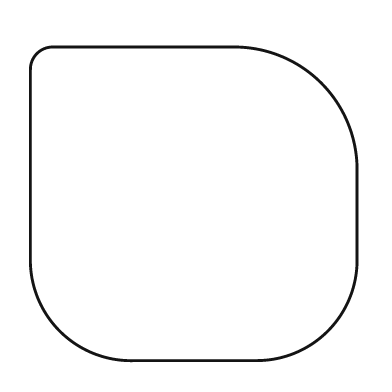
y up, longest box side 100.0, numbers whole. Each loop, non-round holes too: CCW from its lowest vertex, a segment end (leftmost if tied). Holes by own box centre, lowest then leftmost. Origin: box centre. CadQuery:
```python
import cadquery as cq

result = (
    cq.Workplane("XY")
    .moveTo(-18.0, -48.0)
    .lineTo(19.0, -48.0)
    .threePointArc((41.0, -39.0), (50.0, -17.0))
    .lineTo(50.0, 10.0)
    .threePointArc((39.0, 37.0), (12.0, 48.0))
    .lineTo(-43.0, 48.0)
    .threePointArc((-48.0, 46.0), (-50.0, 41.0))
    .lineTo(-50.0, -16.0)
    .threePointArc((-41.0, -39.0), (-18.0, -48.0))
    .close()
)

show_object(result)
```